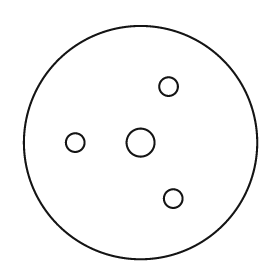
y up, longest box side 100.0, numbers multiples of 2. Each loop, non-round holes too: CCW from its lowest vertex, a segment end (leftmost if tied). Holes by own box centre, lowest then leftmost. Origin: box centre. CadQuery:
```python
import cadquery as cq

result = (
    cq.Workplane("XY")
    .moveTo(0.0, 0.0)
    .circle(50.0)
    .moveTo(14.0, -24.0)
    .circle(4.0)
    .moveTo(-28.0, 0.0)
    .circle(4.0)
    .moveTo(0.0, 0.0)
    .circle(6.0)
    .moveTo(12.0, 24.0)
    .circle(4.0)
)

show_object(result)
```